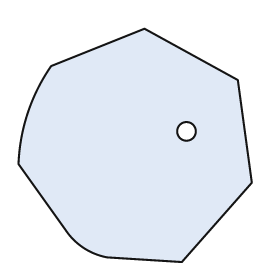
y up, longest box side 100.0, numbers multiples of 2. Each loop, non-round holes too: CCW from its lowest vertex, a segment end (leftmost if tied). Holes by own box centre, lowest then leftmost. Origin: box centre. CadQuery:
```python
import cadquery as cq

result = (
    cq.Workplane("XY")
    .moveTo(20.0, -50.0)
    .lineTo(50.0, -16.0)
    .lineTo(44.0, 28.0)
    .lineTo(4.0, 50.0)
    .lineTo(-36.0, 34.0)
    .threePointArc((-46.0, 14.0), (-50.0, -8.0))
    .lineTo(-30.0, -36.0)
    .threePointArc((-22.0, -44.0), (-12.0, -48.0))
    .close()
    .moveTo(22.0, 6.0)
    .circle(4.0)
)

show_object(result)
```